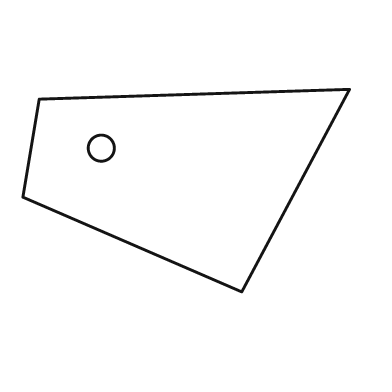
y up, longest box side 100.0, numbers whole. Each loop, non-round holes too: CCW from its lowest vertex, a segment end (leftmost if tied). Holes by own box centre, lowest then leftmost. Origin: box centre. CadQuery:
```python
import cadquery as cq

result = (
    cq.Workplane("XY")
    .moveTo(17.0, -31.0)
    .lineTo(50.0, 31.0)
    .lineTo(-45.0, 28.0)
    .lineTo(-50.0, -2.0)
    .close()
    .moveTo(-26.0, 13.0)
    .circle(4.0)
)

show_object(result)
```